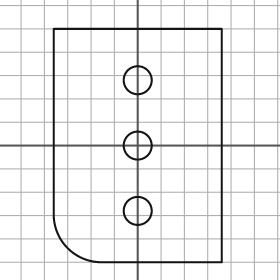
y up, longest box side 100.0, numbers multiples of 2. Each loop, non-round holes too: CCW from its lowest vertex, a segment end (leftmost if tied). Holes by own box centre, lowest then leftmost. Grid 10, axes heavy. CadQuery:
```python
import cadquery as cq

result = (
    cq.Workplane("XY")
    .moveTo(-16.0, -50.0)
    .lineTo(36.0, -50.0)
    .lineTo(36.0, 50.0)
    .lineTo(-36.0, 50.0)
    .lineTo(-36.0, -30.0)
    .threePointArc((-30.0, -44.0), (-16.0, -50.0))
    .close()
    .moveTo(0.0, -28.0)
    .circle(6.0)
    .moveTo(0.0, 0.0)
    .circle(6.0)
    .moveTo(0.0, 28.0)
    .circle(6.0)
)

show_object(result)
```